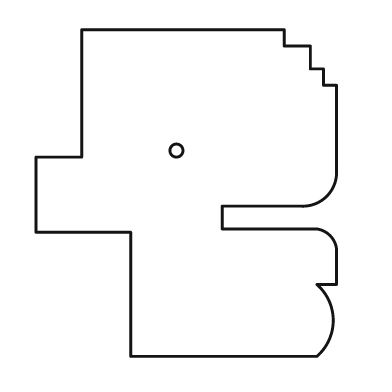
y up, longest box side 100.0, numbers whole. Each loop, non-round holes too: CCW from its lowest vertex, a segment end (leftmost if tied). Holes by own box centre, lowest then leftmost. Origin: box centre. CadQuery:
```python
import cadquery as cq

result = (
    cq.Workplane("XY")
    .moveTo(-17.0, -50.0)
    .lineTo(40.0, -50.0)
    .threePointArc((45.0, -39.0), (40.0, -28.0))
    .lineTo(46.0, -28.0)
    .lineTo(46.0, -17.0)
    .threePointArc((44.0, -13.0), (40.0, -11.0))
    .lineTo(11.0, -11.0)
    .lineTo(11.0, -4.0)
    .lineTo(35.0, -4.0)
    .threePointArc((43.0, -1.0), (46.0, 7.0))
    .lineTo(46.0, 33.0)
    .lineTo(42.0, 33.0)
    .lineTo(42.0, 38.0)
    .lineTo(38.0, 38.0)
    .lineTo(38.0, 45.0)
    .lineTo(30.0, 45.0)
    .lineTo(30.0, 50.0)
    .lineTo(-32.0, 50.0)
    .lineTo(-32.0, 11.0)
    .lineTo(-46.0, 11.0)
    .lineTo(-46.0, -12.0)
    .lineTo(-17.0, -12.0)
    .close()
    .moveTo(-3.0, 13.0)
    .circle(2.0)
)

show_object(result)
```